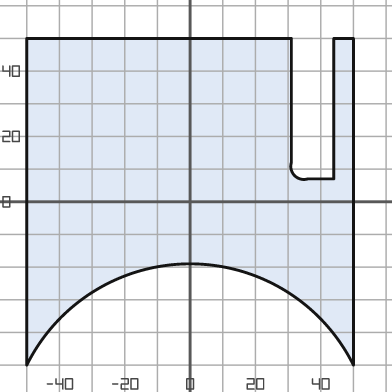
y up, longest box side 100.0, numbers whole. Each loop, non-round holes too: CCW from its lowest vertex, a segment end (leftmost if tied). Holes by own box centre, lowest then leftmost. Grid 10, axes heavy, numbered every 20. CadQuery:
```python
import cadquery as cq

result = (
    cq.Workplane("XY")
    .moveTo(-50.0, -50.0)
    .threePointArc((0.0, -19.0), (50.0, -50.0))
    .lineTo(50.0, 50.0)
    .lineTo(44.0, 50.0)
    .lineTo(44.0, 7.0)
    .lineTo(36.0, 7.0)
    .threePointArc((32.0, 8.0), (31.0, 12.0))
    .lineTo(31.0, 50.0)
    .lineTo(-50.0, 50.0)
    .close()
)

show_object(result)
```